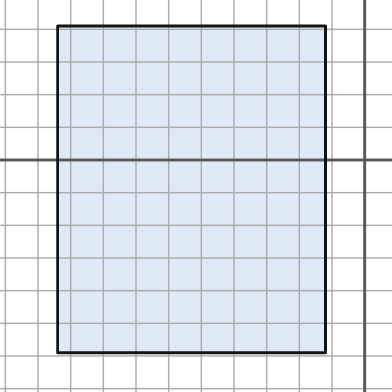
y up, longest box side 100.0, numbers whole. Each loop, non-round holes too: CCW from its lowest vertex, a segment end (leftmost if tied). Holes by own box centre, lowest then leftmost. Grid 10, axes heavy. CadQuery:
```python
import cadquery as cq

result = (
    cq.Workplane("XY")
    .moveTo(-94.0, -59.0)
    .lineTo(-12.0, -59.0)
    .lineTo(-12.0, 41.0)
    .lineTo(-94.0, 41.0)
    .close()
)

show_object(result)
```